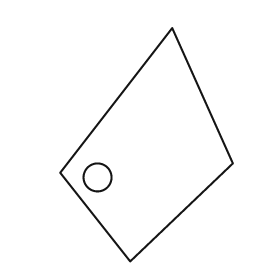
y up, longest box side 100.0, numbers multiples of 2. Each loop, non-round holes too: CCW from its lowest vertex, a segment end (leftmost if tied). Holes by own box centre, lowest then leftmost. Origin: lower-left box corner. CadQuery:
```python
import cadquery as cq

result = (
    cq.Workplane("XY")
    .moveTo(30.0, 0.0)
    .lineTo(74.0, 42.0)
    .lineTo(48.0, 100.0)
    .lineTo(0.0, 38.0)
    .close()
    .moveTo(16.0, 36.0)
    .circle(6.0)
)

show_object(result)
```